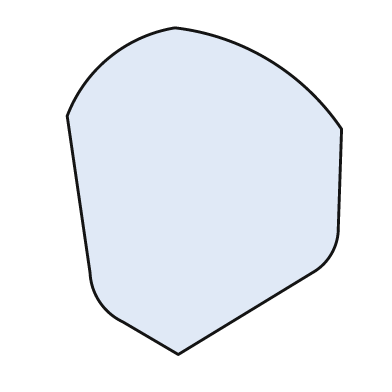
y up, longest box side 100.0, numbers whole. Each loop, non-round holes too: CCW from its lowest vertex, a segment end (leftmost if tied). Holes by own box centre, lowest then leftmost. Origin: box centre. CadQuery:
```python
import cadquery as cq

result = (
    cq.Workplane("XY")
    .moveTo(-8.0, -50.0)
    .lineTo(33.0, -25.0)
    .threePointArc((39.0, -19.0), (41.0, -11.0))
    .lineTo(42.0, 19.0)
    .threePointArc((20.0, 40.0), (-9.0, 50.0))
    .threePointArc((-29.0, 41.0), (-42.0, 23.0))
    .lineTo(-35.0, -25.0)
    .threePointArc((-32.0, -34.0), (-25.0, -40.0))
    .close()
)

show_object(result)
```